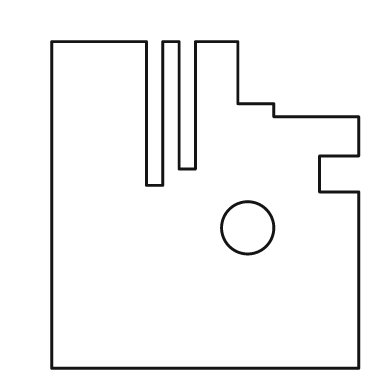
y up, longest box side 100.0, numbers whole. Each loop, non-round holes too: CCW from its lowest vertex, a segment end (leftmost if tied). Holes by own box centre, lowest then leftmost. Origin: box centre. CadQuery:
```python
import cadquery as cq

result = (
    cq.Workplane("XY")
    .moveTo(-47.0, -50.0)
    .lineTo(47.0, -50.0)
    .lineTo(47.0, 4.0)
    .lineTo(35.0, 4.0)
    .lineTo(35.0, 15.0)
    .lineTo(47.0, 15.0)
    .lineTo(47.0, 27.0)
    .lineTo(21.0, 27.0)
    .lineTo(21.0, 31.0)
    .lineTo(10.0, 31.0)
    .lineTo(10.0, 50.0)
    .lineTo(-3.0, 50.0)
    .lineTo(-3.0, 11.0)
    .lineTo(-8.0, 11.0)
    .lineTo(-8.0, 50.0)
    .lineTo(-13.0, 50.0)
    .lineTo(-13.0, 6.0)
    .lineTo(-18.0, 6.0)
    .lineTo(-18.0, 50.0)
    .lineTo(-47.0, 50.0)
    .close()
    .moveTo(13.0, -7.0)
    .circle(8.0)
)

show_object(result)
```